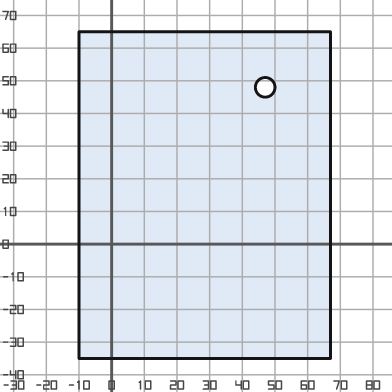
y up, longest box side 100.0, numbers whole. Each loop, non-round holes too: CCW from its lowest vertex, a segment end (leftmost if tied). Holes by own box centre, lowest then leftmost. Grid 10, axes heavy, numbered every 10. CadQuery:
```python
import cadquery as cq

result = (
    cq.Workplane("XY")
    .moveTo(-10.0, -35.0)
    .lineTo(67.0, -35.0)
    .lineTo(67.0, 65.0)
    .lineTo(-10.0, 65.0)
    .close()
    .moveTo(47.0, 48.0)
    .circle(3.0)
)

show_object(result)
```